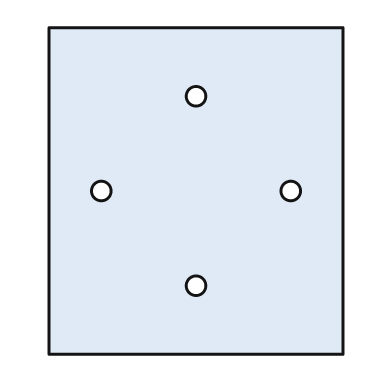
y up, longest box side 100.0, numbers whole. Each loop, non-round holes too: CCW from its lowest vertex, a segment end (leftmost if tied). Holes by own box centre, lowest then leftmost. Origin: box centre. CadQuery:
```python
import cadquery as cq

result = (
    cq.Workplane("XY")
    .moveTo(-45.0, -50.0)
    .lineTo(45.0, -50.0)
    .lineTo(45.0, 50.0)
    .lineTo(-45.0, 50.0)
    .close()
    .moveTo(0.0, -29.0)
    .circle(3.0)
    .moveTo(-29.0, 0.0)
    .circle(3.0)
    .moveTo(29.0, 0.0)
    .circle(3.0)
    .moveTo(0.0, 29.0)
    .circle(3.0)
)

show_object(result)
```